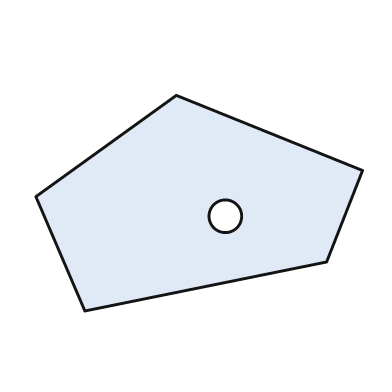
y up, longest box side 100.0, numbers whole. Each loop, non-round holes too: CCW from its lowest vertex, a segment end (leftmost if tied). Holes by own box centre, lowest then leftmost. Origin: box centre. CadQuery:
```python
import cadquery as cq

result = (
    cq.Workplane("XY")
    .moveTo(-35.0, -33.0)
    .lineTo(39.0, -18.0)
    .lineTo(50.0, 10.0)
    .lineTo(-7.0, 33.0)
    .lineTo(-50.0, 2.0)
    .close()
    .moveTo(8.0, -4.0)
    .circle(5.0)
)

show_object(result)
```